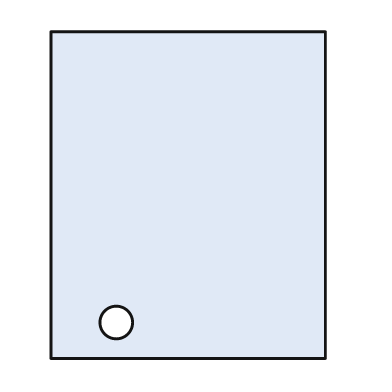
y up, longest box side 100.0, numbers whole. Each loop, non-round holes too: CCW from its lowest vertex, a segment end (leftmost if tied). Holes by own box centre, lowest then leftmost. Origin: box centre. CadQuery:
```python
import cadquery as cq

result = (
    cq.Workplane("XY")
    .moveTo(-42.0, -50.0)
    .lineTo(42.0, -50.0)
    .lineTo(42.0, 50.0)
    .lineTo(-42.0, 50.0)
    .close()
    .moveTo(-22.0, -39.0)
    .circle(5.0)
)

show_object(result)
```